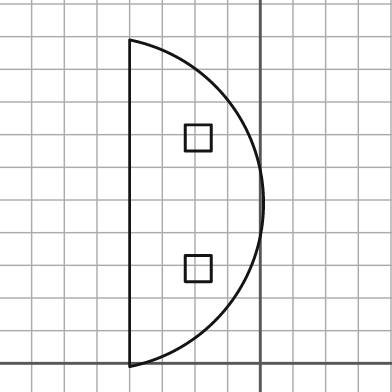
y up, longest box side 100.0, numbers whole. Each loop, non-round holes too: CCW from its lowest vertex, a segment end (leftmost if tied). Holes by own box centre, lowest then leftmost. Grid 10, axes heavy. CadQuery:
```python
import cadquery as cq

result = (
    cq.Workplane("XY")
    .moveTo(-40.0, -1.0)
    .threePointArc((1.0, 49.0), (-40.0, 99.0))
    .close()
    .moveTo(-23.0, 25.0)
    .lineTo(-15.0, 25.0)
    .lineTo(-15.0, 33.0)
    .lineTo(-23.0, 33.0)
    .close()
    .moveTo(-23.0, 65.0)
    .lineTo(-15.0, 65.0)
    .lineTo(-15.0, 73.0)
    .lineTo(-23.0, 73.0)
    .close()
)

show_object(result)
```